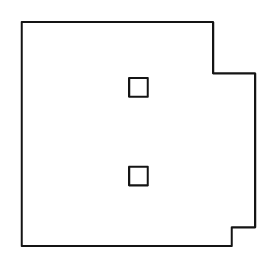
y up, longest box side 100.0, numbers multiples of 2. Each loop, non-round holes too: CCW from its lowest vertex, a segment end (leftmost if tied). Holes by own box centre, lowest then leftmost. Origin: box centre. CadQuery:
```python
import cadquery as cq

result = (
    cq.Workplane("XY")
    .moveTo(-50.0, -48.0)
    .lineTo(40.0, -48.0)
    .lineTo(40.0, -40.0)
    .lineTo(50.0, -40.0)
    .lineTo(50.0, 26.0)
    .lineTo(32.0, 26.0)
    .lineTo(32.0, 48.0)
    .lineTo(-50.0, 48.0)
    .close()
    .moveTo(-4.0, -22.0)
    .lineTo(4.0, -22.0)
    .lineTo(4.0, -14.0)
    .lineTo(-4.0, -14.0)
    .close()
    .moveTo(-4.0, 16.0)
    .lineTo(4.0, 16.0)
    .lineTo(4.0, 24.0)
    .lineTo(-4.0, 24.0)
    .close()
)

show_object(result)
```